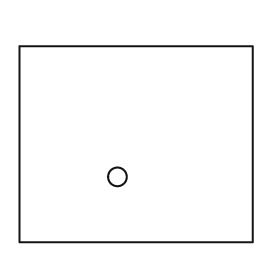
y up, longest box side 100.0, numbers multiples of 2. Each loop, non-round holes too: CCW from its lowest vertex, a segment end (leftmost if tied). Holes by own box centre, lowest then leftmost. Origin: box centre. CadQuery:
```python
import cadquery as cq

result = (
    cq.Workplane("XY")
    .moveTo(-50.0, -42.0)
    .lineTo(50.0, -42.0)
    .lineTo(50.0, 42.0)
    .lineTo(-50.0, 42.0)
    .close()
    .moveTo(-8.0, -14.0)
    .circle(4.0)
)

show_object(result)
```